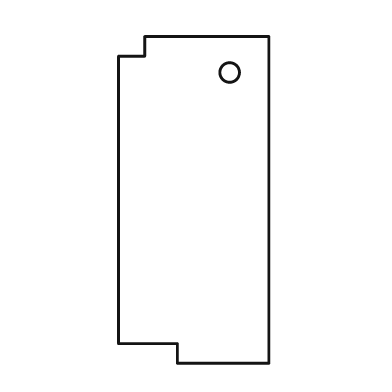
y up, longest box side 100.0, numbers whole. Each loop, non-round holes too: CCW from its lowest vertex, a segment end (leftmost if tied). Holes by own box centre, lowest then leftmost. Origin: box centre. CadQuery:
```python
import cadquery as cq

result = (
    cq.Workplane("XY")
    .moveTo(-5.0, -50.0)
    .lineTo(23.0, -50.0)
    .lineTo(23.0, 50.0)
    .lineTo(-15.0, 50.0)
    .lineTo(-15.0, 44.0)
    .lineTo(-23.0, 44.0)
    .lineTo(-23.0, -44.0)
    .lineTo(-5.0, -44.0)
    .close()
    .moveTo(11.0, 39.0)
    .circle(3.0)
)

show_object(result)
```